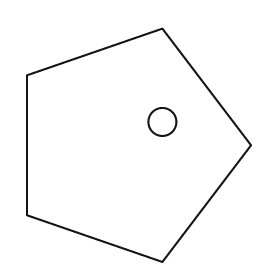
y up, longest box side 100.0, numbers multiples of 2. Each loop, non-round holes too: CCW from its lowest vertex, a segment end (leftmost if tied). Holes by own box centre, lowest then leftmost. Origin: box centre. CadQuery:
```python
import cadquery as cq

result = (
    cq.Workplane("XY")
    .moveTo(10.0, -50.0)
    .lineTo(48.0, 0.0)
    .lineTo(10.0, 50.0)
    .lineTo(-48.0, 30.0)
    .lineTo(-48.0, -30.0)
    .close()
    .moveTo(10.0, 10.0)
    .circle(6.0)
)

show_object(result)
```